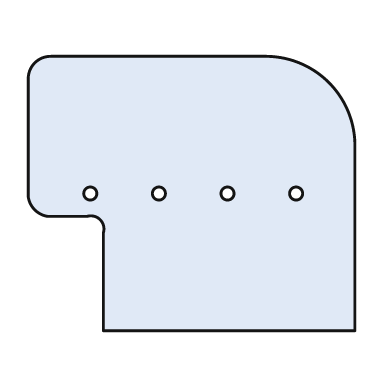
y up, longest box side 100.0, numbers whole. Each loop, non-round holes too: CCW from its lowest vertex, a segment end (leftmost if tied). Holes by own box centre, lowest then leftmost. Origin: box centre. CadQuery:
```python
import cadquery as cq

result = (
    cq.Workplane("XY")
    .moveTo(-27.0, -42.0)
    .lineTo(50.0, -42.0)
    .lineTo(50.0, 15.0)
    .threePointArc((42.0, 34.0), (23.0, 42.0))
    .lineTo(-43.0, 42.0)
    .threePointArc((-48.0, 40.0), (-50.0, 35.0))
    .lineTo(-50.0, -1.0)
    .threePointArc((-48.0, -5.0), (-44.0, -7.0))
    .lineTo(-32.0, -7.0)
    .threePointArc((-28.0, -8.0), (-27.0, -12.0))
    .close()
    .moveTo(-31.0, 0.0)
    .circle(2.0)
    .moveTo(-10.0, 0.0)
    .circle(2.0)
    .moveTo(11.0, 0.0)
    .circle(2.0)
    .moveTo(32.0, 0.0)
    .circle(2.0)
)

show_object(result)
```